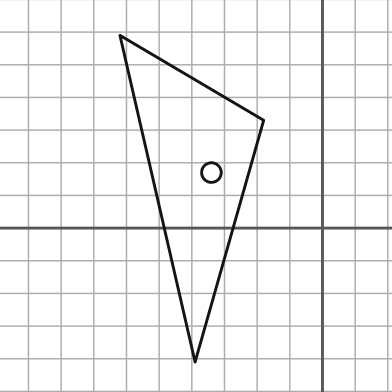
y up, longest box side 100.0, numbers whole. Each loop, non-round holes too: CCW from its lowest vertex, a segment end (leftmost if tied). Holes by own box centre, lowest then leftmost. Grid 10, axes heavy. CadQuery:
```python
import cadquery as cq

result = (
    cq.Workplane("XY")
    .moveTo(-39.0, -41.0)
    .lineTo(-18.0, 33.0)
    .lineTo(-62.0, 59.0)
    .close()
    .moveTo(-34.0, 17.0)
    .circle(3.0)
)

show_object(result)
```